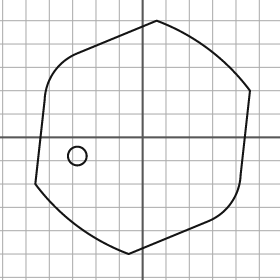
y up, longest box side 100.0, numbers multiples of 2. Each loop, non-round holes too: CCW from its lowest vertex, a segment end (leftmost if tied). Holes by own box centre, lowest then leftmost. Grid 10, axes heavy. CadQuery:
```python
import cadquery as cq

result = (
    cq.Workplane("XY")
    .moveTo(-6.0, -50.0)
    .lineTo(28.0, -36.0)
    .threePointArc((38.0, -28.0), (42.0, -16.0))
    .lineTo(46.0, 20.0)
    .threePointArc((28.0, 38.0), (6.0, 50.0))
    .lineTo(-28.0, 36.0)
    .threePointArc((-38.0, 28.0), (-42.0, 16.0))
    .lineTo(-46.0, -20.0)
    .threePointArc((-28.0, -38.0), (-6.0, -50.0))
    .close()
    .moveTo(-28.0, -8.0)
    .circle(4.0)
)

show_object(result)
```